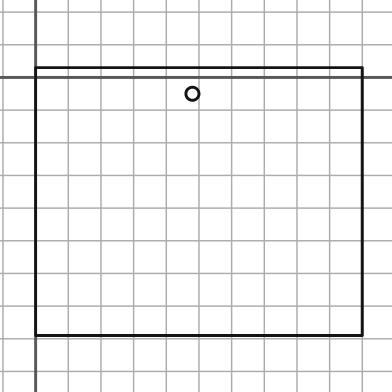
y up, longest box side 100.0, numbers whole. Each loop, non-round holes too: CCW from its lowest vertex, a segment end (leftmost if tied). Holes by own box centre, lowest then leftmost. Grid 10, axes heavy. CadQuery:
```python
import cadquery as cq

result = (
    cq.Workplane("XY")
    .moveTo(0.0, -79.0)
    .lineTo(100.0, -79.0)
    .lineTo(100.0, 3.0)
    .lineTo(0.0, 3.0)
    .close()
    .moveTo(48.0, -5.0)
    .circle(2.0)
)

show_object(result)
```